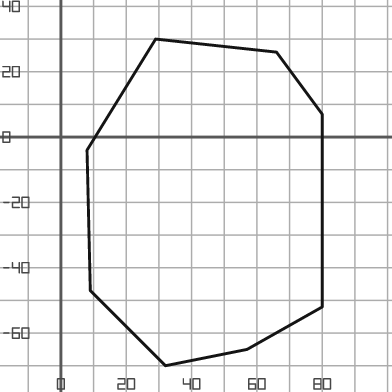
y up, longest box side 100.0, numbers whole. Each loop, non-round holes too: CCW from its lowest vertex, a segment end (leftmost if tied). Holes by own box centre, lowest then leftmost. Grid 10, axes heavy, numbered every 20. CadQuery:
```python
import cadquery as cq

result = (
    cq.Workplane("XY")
    .moveTo(32.0, -70.0)
    .lineTo(57.0, -65.0)
    .lineTo(80.0, -52.0)
    .lineTo(80.0, 7.0)
    .lineTo(66.0, 26.0)
    .lineTo(29.0, 30.0)
    .lineTo(8.0, -4.0)
    .lineTo(9.0, -47.0)
    .close()
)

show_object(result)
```